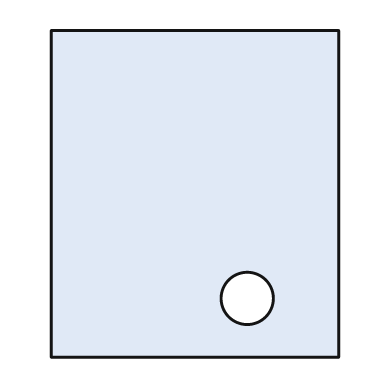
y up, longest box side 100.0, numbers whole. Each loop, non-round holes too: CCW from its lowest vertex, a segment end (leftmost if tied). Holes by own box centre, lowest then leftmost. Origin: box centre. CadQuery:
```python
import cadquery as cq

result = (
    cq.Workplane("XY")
    .moveTo(-44.0, -50.0)
    .lineTo(44.0, -50.0)
    .lineTo(44.0, 50.0)
    .lineTo(-44.0, 50.0)
    .close()
    .moveTo(16.0, -32.0)
    .circle(8.0)
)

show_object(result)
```